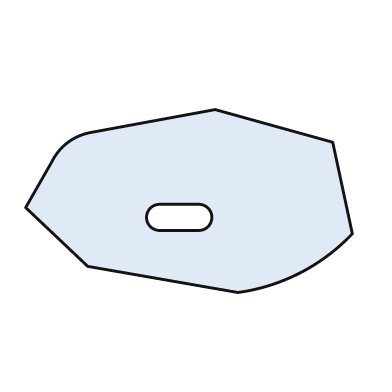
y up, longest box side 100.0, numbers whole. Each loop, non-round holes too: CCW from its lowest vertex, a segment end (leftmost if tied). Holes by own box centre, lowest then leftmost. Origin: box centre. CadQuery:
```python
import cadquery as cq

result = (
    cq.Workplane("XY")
    .moveTo(15.0, -28.0)
    .threePointArc((34.0, -22.0), (50.0, -10.0))
    .lineTo(44.0, 18.0)
    .lineTo(8.0, 28.0)
    .lineTo(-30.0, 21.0)
    .threePointArc((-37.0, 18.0), (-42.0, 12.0))
    .lineTo(-50.0, -2.0)
    .lineTo(-31.0, -20.0)
    .close()
    .moveTo(-9.0, -9.0)
    .lineTo(3.0, -9.0)
    .threePointArc((7.0, -5.0), (3.0, -1.0))
    .lineTo(-9.0, -1.0)
    .threePointArc((-13.0, -5.0), (-9.0, -9.0))
    .close()
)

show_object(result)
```